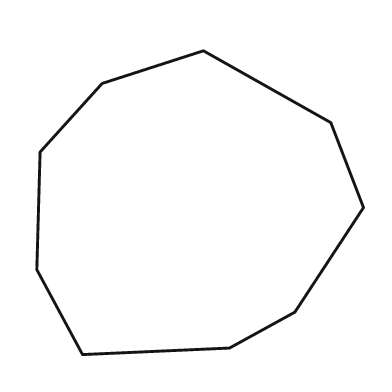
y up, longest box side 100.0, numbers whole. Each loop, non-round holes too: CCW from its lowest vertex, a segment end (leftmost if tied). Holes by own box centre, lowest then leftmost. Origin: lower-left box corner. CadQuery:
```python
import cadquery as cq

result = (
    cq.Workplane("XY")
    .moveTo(14.0, 0.0)
    .lineTo(59.0, 2.0)
    .lineTo(79.0, 13.0)
    .lineTo(100.0, 45.0)
    .lineTo(90.0, 71.0)
    .lineTo(51.0, 93.0)
    .lineTo(20.0, 83.0)
    .lineTo(1.0, 62.0)
    .lineTo(0.0, 26.0)
    .close()
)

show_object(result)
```